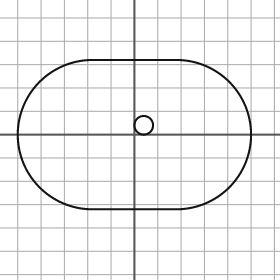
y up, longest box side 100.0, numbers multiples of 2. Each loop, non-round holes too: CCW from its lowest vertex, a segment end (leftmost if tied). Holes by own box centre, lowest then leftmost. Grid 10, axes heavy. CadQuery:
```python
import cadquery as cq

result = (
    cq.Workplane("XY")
    .moveTo(-18.0, -32.0)
    .lineTo(18.0, -32.0)
    .threePointArc((50.0, 0.0), (18.0, 32.0))
    .lineTo(-18.0, 32.0)
    .threePointArc((-50.0, 0.0), (-18.0, -32.0))
    .close()
    .moveTo(4.0, 4.0)
    .circle(4.0)
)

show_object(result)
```